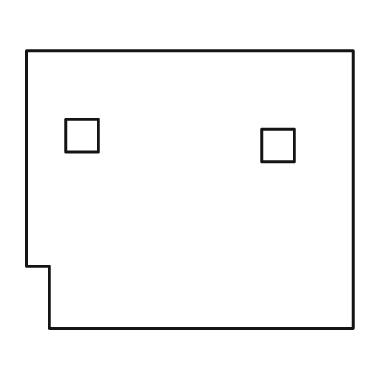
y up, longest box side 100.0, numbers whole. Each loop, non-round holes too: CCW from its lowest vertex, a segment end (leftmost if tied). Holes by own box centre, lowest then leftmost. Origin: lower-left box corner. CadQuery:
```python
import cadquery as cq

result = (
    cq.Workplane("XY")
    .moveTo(7.0, 0.0)
    .lineTo(100.0, 0.0)
    .lineTo(100.0, 85.0)
    .lineTo(0.0, 85.0)
    .lineTo(0.0, 19.0)
    .lineTo(7.0, 19.0)
    .close()
    .moveTo(72.0, 51.0)
    .lineTo(82.0, 51.0)
    .lineTo(82.0, 61.0)
    .lineTo(72.0, 61.0)
    .close()
    .moveTo(12.0, 54.0)
    .lineTo(22.0, 54.0)
    .lineTo(22.0, 64.0)
    .lineTo(12.0, 64.0)
    .close()
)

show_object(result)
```